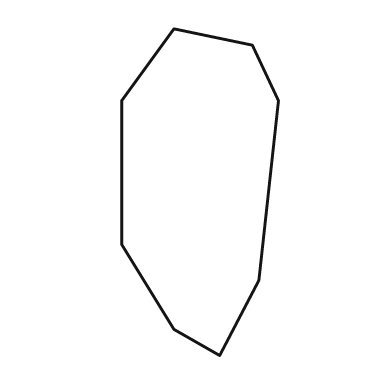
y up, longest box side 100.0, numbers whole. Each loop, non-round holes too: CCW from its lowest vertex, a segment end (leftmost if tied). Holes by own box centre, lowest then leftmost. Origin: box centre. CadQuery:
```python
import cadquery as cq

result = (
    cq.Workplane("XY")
    .moveTo(6.0, -50.0)
    .lineTo(18.0, -27.0)
    .lineTo(24.0, 28.0)
    .lineTo(16.0, 45.0)
    .lineTo(-8.0, 50.0)
    .lineTo(-24.0, 28.0)
    .lineTo(-24.0, -16.0)
    .lineTo(-8.0, -42.0)
    .close()
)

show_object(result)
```